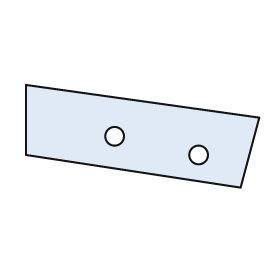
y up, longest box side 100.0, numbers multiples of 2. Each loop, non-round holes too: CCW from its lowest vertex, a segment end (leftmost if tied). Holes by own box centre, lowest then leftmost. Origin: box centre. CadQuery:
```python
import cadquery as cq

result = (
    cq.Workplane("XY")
    .moveTo(42.0, -22.0)
    .lineTo(50.0, 8.0)
    .lineTo(-50.0, 22.0)
    .lineTo(-50.0, -8.0)
    .close()
    .moveTo(24.0, -8.0)
    .circle(4.0)
    .moveTo(-12.0, 0.0)
    .circle(4.0)
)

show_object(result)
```